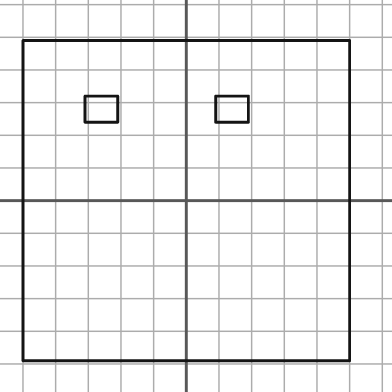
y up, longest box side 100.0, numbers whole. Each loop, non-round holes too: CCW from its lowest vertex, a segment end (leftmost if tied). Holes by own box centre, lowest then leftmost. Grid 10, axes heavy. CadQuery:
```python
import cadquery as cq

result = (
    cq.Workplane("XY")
    .moveTo(-50.0, -49.0)
    .lineTo(50.0, -49.0)
    .lineTo(50.0, 49.0)
    .lineTo(-50.0, 49.0)
    .close()
    .moveTo(-31.0, 24.0)
    .lineTo(-21.0, 24.0)
    .lineTo(-21.0, 32.0)
    .lineTo(-31.0, 32.0)
    .close()
    .moveTo(9.0, 24.0)
    .lineTo(19.0, 24.0)
    .lineTo(19.0, 32.0)
    .lineTo(9.0, 32.0)
    .close()
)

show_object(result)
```